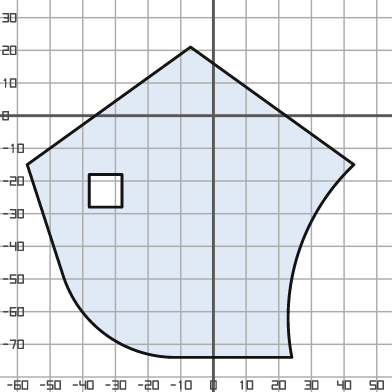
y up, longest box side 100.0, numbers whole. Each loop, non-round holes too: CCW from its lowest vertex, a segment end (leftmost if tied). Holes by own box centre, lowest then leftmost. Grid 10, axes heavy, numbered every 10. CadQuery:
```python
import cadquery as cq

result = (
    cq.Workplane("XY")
    .moveTo(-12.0, -74.0)
    .lineTo(24.0, -74.0)
    .threePointArc((26.0, -42.0), (43.0, -15.0))
    .lineTo(-7.0, 21.0)
    .lineTo(-57.0, -15.0)
    .lineTo(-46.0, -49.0)
    .threePointArc((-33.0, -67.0), (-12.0, -74.0))
    .close()
    .moveTo(-38.0, -28.0)
    .lineTo(-28.0, -28.0)
    .lineTo(-28.0, -18.0)
    .lineTo(-38.0, -18.0)
    .close()
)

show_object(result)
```